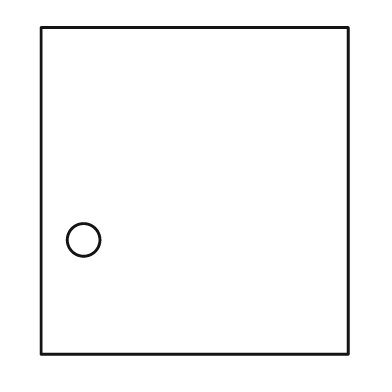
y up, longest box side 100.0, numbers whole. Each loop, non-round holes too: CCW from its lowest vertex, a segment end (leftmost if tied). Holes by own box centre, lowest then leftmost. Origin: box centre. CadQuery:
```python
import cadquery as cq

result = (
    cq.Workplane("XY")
    .moveTo(-47.0, -50.0)
    .lineTo(47.0, -50.0)
    .lineTo(47.0, 50.0)
    .lineTo(-47.0, 50.0)
    .close()
    .moveTo(-34.0, -15.0)
    .circle(5.0)
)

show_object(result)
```